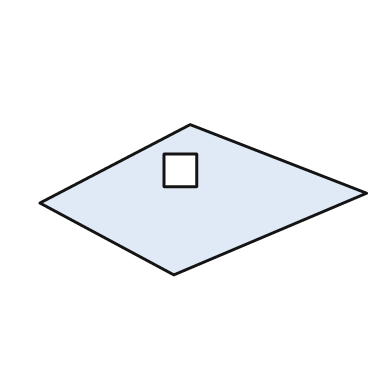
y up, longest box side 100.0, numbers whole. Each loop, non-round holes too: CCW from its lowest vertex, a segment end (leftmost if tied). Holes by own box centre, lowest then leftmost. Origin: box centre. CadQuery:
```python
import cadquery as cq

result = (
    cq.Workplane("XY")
    .moveTo(-9.0, -23.0)
    .lineTo(50.0, 2.0)
    .lineTo(-4.0, 23.0)
    .lineTo(-50.0, -1.0)
    .close()
    .moveTo(-12.0, 4.0)
    .lineTo(-2.0, 4.0)
    .lineTo(-2.0, 14.0)
    .lineTo(-12.0, 14.0)
    .close()
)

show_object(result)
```